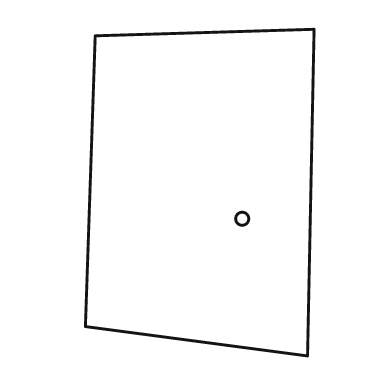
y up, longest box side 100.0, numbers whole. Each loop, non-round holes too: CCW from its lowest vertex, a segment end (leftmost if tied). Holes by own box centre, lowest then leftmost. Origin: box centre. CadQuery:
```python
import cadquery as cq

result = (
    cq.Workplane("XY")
    .moveTo(33.0, -50.0)
    .lineTo(35.0, 50.0)
    .lineTo(-32.0, 48.0)
    .lineTo(-35.0, -41.0)
    .close()
    .moveTo(13.0, -8.0)
    .circle(2.0)
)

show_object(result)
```